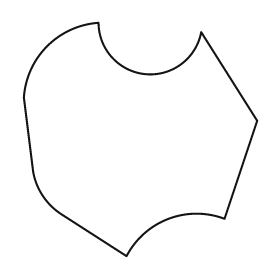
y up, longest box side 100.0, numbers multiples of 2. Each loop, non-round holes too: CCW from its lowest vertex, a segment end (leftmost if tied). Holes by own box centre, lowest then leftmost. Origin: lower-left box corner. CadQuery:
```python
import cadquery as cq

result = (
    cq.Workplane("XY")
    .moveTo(44.0, 0.0)
    .threePointArc((62.0, 16.0), (86.0, 16.0))
    .lineTo(100.0, 58.0)
    .lineTo(76.0, 96.0)
    .threePointArc((52.0, 78.0), (32.0, 100.0))
    .threePointArc((10.0, 90.0), (0.0, 68.0))
    .lineTo(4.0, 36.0)
    .threePointArc((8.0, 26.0), (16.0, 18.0))
    .close()
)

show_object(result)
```